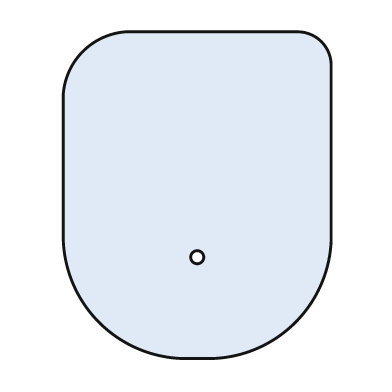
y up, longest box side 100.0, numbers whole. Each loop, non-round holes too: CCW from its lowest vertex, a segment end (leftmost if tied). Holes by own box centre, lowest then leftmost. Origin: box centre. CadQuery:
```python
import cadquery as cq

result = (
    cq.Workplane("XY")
    .moveTo(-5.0, -50.0)
    .lineTo(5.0, -50.0)
    .threePointArc((30.0, -39.0), (41.0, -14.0))
    .lineTo(41.0, 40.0)
    .threePointArc((38.0, 47.0), (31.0, 50.0))
    .lineTo(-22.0, 50.0)
    .threePointArc((-35.0, 44.0), (-41.0, 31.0))
    .lineTo(-41.0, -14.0)
    .threePointArc((-30.0, -39.0), (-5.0, -50.0))
    .close()
    .moveTo(0.0, -19.0)
    .circle(2.0)
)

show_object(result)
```